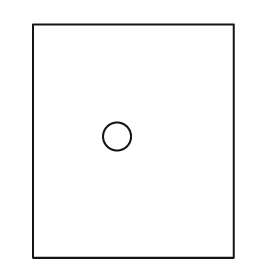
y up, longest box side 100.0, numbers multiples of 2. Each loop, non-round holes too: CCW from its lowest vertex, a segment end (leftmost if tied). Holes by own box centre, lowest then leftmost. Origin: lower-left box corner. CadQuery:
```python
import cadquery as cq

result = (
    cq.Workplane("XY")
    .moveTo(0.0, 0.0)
    .lineTo(86.0, 0.0)
    .lineTo(86.0, 100.0)
    .lineTo(0.0, 100.0)
    .close()
    .moveTo(36.0, 52.0)
    .circle(6.0)
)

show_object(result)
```